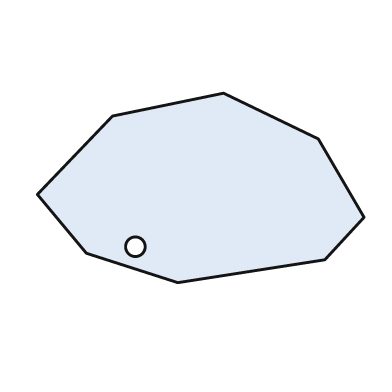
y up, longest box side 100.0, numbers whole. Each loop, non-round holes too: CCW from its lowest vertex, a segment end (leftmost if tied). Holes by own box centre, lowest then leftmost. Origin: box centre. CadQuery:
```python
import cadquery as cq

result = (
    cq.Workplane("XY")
    .moveTo(-7.0, -29.0)
    .lineTo(38.0, -22.0)
    .lineTo(50.0, -9.0)
    .lineTo(36.0, 15.0)
    .lineTo(7.0, 29.0)
    .lineTo(-27.0, 22.0)
    .lineTo(-50.0, -2.0)
    .lineTo(-35.0, -20.0)
    .close()
    .moveTo(-20.0, -18.0)
    .circle(3.0)
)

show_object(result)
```